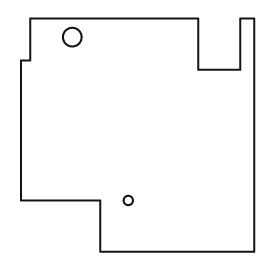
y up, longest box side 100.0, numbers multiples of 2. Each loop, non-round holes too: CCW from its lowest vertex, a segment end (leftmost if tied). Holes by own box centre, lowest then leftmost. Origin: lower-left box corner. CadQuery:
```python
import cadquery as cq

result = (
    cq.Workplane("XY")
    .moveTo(34.0, 0.0)
    .lineTo(100.0, 0.0)
    .lineTo(100.0, 100.0)
    .lineTo(94.0, 100.0)
    .lineTo(94.0, 78.0)
    .lineTo(76.0, 78.0)
    .lineTo(76.0, 100.0)
    .lineTo(4.0, 100.0)
    .lineTo(4.0, 82.0)
    .lineTo(0.0, 82.0)
    .lineTo(0.0, 22.0)
    .lineTo(34.0, 22.0)
    .close()
    .moveTo(46.0, 22.0)
    .circle(2.0)
    .moveTo(22.0, 92.0)
    .circle(4.0)
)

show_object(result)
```